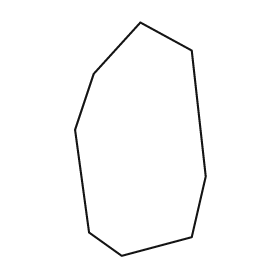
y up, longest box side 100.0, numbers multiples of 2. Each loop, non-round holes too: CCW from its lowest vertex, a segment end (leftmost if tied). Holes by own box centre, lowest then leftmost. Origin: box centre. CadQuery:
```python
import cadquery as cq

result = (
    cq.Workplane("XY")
    .moveTo(-8.0, -50.0)
    .lineTo(22.0, -42.0)
    .lineTo(28.0, -16.0)
    .lineTo(22.0, 38.0)
    .lineTo(0.0, 50.0)
    .lineTo(-20.0, 28.0)
    .lineTo(-28.0, 4.0)
    .lineTo(-22.0, -40.0)
    .close()
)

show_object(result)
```